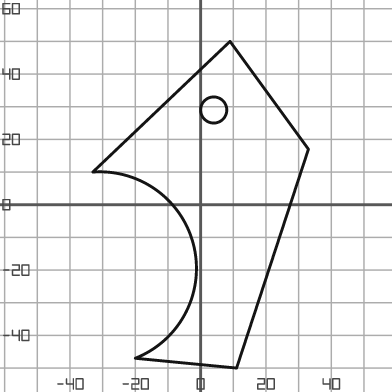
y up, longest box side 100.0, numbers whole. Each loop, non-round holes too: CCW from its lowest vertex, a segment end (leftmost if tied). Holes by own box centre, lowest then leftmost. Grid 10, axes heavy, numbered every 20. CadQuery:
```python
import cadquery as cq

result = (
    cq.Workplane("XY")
    .moveTo(11.0, -50.0)
    .lineTo(33.0, 17.0)
    .lineTo(9.0, 50.0)
    .lineTo(-33.0, 10.0)
    .threePointArc((-2.0, -13.0), (-20.0, -47.0))
    .close()
    .moveTo(4.0, 29.0)
    .circle(4.0)
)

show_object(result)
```